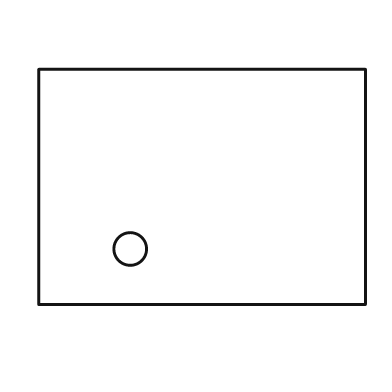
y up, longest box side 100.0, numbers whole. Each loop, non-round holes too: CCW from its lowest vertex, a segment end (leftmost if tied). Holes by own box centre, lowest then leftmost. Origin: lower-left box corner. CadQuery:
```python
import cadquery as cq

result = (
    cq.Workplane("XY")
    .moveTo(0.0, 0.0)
    .lineTo(100.0, 0.0)
    .lineTo(100.0, 72.0)
    .lineTo(0.0, 72.0)
    .close()
    .moveTo(28.0, 17.0)
    .circle(5.0)
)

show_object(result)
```